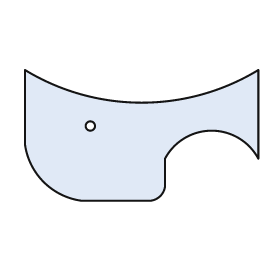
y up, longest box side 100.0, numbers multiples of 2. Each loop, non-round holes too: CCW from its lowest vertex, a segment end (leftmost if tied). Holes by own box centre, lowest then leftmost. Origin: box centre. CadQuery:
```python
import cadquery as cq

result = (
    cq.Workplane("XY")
    .moveTo(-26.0, -28.0)
    .lineTo(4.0, -28.0)
    .threePointArc((8.0, -26.0), (10.0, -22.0))
    .lineTo(10.0, -10.0)
    .threePointArc((30.0, 2.0), (50.0, -10.0))
    .lineTo(50.0, 28.0)
    .threePointArc((0.0, 14.0), (-50.0, 28.0))
    .lineTo(-50.0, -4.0)
    .threePointArc((-42.0, -20.0), (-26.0, -28.0))
    .close()
    .moveTo(-22.0, 4.0)
    .circle(2.0)
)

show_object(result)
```